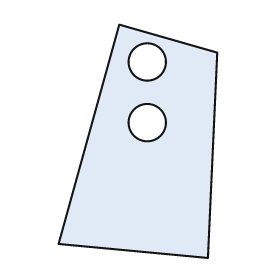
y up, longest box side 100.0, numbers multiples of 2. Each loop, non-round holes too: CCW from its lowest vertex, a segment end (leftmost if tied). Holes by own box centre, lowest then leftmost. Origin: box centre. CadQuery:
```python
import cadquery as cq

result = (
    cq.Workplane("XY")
    .moveTo(30.0, -50.0)
    .lineTo(34.0, 38.0)
    .lineTo(-8.0, 50.0)
    .lineTo(-34.0, -44.0)
    .close()
    .moveTo(4.0, 8.0)
    .circle(8.0)
    .moveTo(4.0, 34.0)
    .circle(8.0)
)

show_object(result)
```